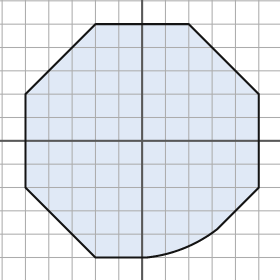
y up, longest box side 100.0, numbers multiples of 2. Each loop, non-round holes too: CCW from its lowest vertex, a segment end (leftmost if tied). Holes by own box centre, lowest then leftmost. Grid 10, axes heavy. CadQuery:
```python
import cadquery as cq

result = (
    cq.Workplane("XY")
    .moveTo(-20.0, -50.0)
    .lineTo(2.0, -50.0)
    .threePointArc((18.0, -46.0), (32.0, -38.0))
    .lineTo(50.0, -20.0)
    .lineTo(50.0, 20.0)
    .lineTo(20.0, 50.0)
    .lineTo(-20.0, 50.0)
    .lineTo(-50.0, 20.0)
    .lineTo(-50.0, -20.0)
    .close()
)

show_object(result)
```